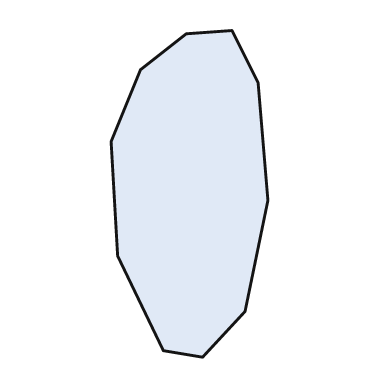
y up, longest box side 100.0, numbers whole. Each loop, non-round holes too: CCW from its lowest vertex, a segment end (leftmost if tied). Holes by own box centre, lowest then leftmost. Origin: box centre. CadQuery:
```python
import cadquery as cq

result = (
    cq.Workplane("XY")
    .moveTo(4.0, -50.0)
    .lineTo(17.0, -36.0)
    .lineTo(24.0, -2.0)
    .lineTo(21.0, 34.0)
    .lineTo(13.0, 50.0)
    .lineTo(-1.0, 49.0)
    .lineTo(-15.0, 38.0)
    .lineTo(-24.0, 16.0)
    .lineTo(-22.0, -19.0)
    .lineTo(-8.0, -48.0)
    .close()
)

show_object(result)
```